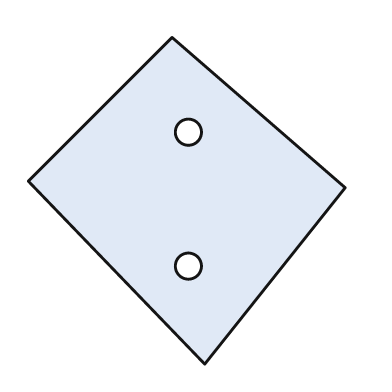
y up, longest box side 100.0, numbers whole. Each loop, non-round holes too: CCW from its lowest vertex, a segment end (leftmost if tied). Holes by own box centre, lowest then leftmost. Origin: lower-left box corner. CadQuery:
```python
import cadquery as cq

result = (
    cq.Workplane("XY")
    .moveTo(54.0, 0.0)
    .lineTo(97.0, 54.0)
    .lineTo(44.0, 100.0)
    .lineTo(0.0, 56.0)
    .close()
    .moveTo(49.0, 30.0)
    .circle(4.0)
    .moveTo(49.0, 71.0)
    .circle(4.0)
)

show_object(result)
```